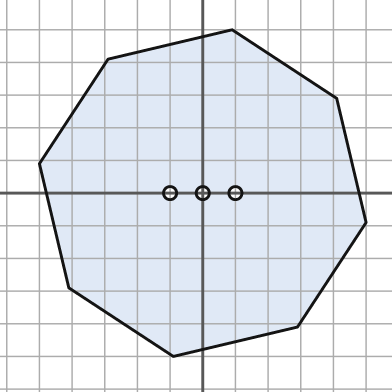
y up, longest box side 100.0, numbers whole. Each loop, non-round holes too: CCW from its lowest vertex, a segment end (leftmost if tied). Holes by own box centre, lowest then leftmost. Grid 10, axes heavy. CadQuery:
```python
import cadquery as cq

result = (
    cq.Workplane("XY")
    .moveTo(-9.0, -50.0)
    .lineTo(29.0, -41.0)
    .lineTo(50.0, -9.0)
    .lineTo(41.0, 29.0)
    .lineTo(9.0, 50.0)
    .lineTo(-29.0, 41.0)
    .lineTo(-50.0, 9.0)
    .lineTo(-41.0, -29.0)
    .close()
    .moveTo(-10.0, 0.0)
    .circle(2.0)
    .moveTo(0.0, 0.0)
    .circle(2.0)
    .moveTo(10.0, 0.0)
    .circle(2.0)
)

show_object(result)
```